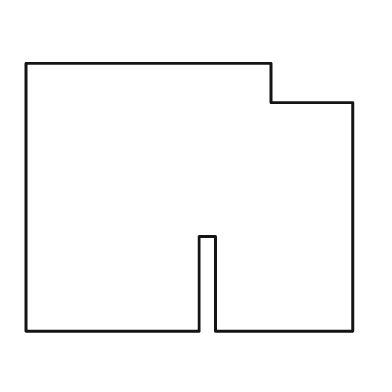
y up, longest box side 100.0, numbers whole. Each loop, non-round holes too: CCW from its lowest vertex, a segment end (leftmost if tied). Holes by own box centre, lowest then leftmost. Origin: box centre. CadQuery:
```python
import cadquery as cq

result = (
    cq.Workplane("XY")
    .moveTo(-50.0, -41.0)
    .lineTo(3.0, -41.0)
    .lineTo(3.0, -12.0)
    .lineTo(8.0, -12.0)
    .lineTo(8.0, -41.0)
    .lineTo(50.0, -41.0)
    .lineTo(50.0, 29.0)
    .lineTo(25.0, 29.0)
    .lineTo(25.0, 41.0)
    .lineTo(-50.0, 41.0)
    .close()
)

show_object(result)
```